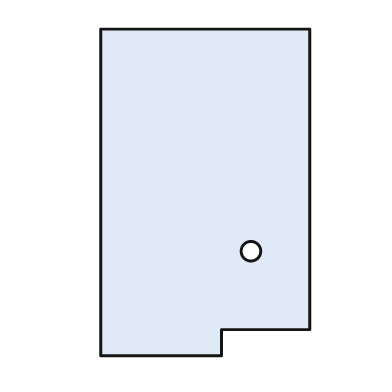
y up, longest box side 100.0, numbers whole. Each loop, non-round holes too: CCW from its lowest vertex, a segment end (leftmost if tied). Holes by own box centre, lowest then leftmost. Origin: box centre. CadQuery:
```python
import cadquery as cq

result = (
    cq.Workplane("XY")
    .moveTo(-32.0, -50.0)
    .lineTo(5.0, -50.0)
    .lineTo(5.0, -42.0)
    .lineTo(32.0, -42.0)
    .lineTo(32.0, 50.0)
    .lineTo(-32.0, 50.0)
    .close()
    .moveTo(14.0, -18.0)
    .circle(3.0)
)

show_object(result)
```